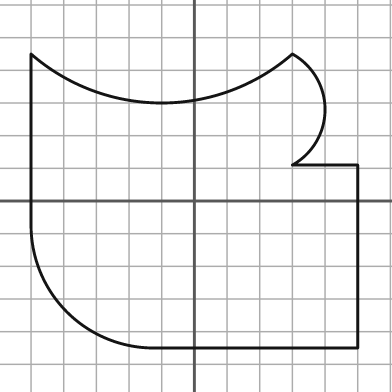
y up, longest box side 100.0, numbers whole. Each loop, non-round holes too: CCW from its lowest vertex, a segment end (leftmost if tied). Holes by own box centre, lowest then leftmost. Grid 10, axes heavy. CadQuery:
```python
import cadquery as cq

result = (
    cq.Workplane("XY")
    .moveTo(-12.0, -45.0)
    .lineTo(50.0, -45.0)
    .lineTo(50.0, 11.0)
    .lineTo(30.0, 11.0)
    .threePointArc((40.0, 28.0), (30.0, 45.0))
    .threePointArc((-10.0, 30.0), (-50.0, 45.0))
    .lineTo(-50.0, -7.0)
    .threePointArc((-39.0, -34.0), (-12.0, -45.0))
    .close()
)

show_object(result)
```